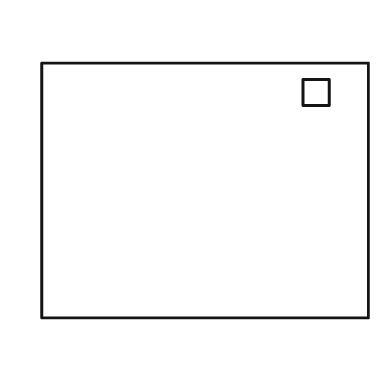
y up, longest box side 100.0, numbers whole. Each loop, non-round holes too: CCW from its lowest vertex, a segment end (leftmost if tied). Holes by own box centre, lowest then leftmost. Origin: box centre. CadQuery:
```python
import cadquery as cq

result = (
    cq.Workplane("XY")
    .moveTo(-50.0, -39.0)
    .lineTo(50.0, -39.0)
    .lineTo(50.0, 39.0)
    .lineTo(-50.0, 39.0)
    .close()
    .moveTo(30.0, 26.0)
    .lineTo(38.0, 26.0)
    .lineTo(38.0, 34.0)
    .lineTo(30.0, 34.0)
    .close()
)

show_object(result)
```